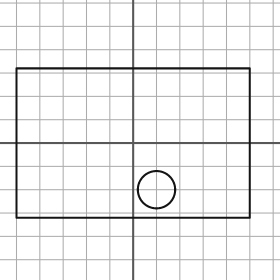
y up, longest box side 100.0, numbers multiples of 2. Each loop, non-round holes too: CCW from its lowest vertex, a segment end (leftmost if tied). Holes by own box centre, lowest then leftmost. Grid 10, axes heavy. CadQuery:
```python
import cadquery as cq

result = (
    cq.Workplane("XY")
    .moveTo(-50.0, -32.0)
    .lineTo(50.0, -32.0)
    .lineTo(50.0, 32.0)
    .lineTo(-50.0, 32.0)
    .close()
    .moveTo(10.0, -20.0)
    .circle(8.0)
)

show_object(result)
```